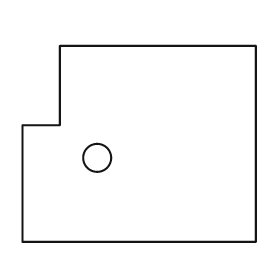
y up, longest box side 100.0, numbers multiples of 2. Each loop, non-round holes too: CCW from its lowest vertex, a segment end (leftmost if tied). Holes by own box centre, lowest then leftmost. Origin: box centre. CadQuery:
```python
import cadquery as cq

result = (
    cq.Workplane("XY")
    .moveTo(-50.0, -42.0)
    .lineTo(50.0, -42.0)
    .lineTo(50.0, 42.0)
    .lineTo(-34.0, 42.0)
    .lineTo(-34.0, 8.0)
    .lineTo(-50.0, 8.0)
    .close()
    .moveTo(-18.0, -6.0)
    .circle(6.0)
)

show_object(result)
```